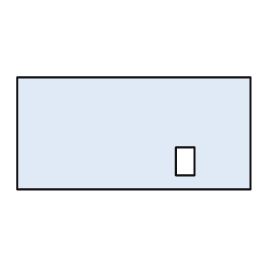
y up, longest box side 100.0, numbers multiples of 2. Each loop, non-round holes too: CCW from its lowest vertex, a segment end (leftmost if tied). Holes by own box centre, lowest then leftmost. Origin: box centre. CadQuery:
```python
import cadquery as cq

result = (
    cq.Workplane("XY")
    .moveTo(-50.0, -24.0)
    .lineTo(50.0, -24.0)
    .lineTo(50.0, 24.0)
    .lineTo(-50.0, 24.0)
    .close()
    .moveTo(18.0, -18.0)
    .lineTo(26.0, -18.0)
    .lineTo(26.0, -6.0)
    .lineTo(18.0, -6.0)
    .close()
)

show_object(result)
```